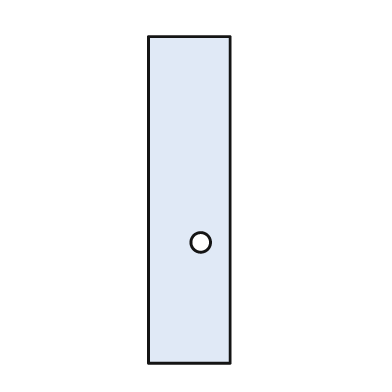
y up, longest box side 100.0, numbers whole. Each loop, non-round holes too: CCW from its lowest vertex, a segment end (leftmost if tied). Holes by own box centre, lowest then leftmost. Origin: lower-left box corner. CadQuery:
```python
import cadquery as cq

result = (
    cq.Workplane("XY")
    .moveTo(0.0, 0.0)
    .lineTo(25.0, 0.0)
    .lineTo(25.0, 100.0)
    .lineTo(0.0, 100.0)
    .close()
    .moveTo(16.0, 37.0)
    .circle(3.0)
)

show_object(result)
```